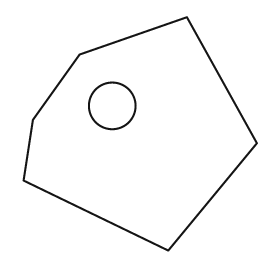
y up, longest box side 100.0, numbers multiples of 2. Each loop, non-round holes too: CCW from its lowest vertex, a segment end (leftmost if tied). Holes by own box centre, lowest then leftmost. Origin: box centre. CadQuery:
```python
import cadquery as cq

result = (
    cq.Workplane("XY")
    .moveTo(12.0, -50.0)
    .lineTo(50.0, -4.0)
    .lineTo(20.0, 50.0)
    .lineTo(-26.0, 34.0)
    .lineTo(-46.0, 6.0)
    .lineTo(-50.0, -20.0)
    .close()
    .moveTo(-12.0, 12.0)
    .circle(10.0)
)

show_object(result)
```